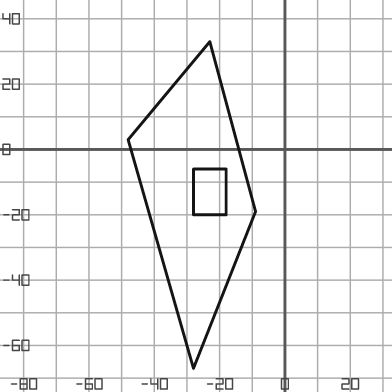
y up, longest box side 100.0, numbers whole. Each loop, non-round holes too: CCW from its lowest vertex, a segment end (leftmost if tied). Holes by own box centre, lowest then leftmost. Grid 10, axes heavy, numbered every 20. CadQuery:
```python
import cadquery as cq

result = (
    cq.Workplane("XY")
    .moveTo(-28.0, -67.0)
    .lineTo(-9.0, -19.0)
    .lineTo(-23.0, 33.0)
    .lineTo(-48.0, 3.0)
    .close()
    .moveTo(-28.0, -20.0)
    .lineTo(-18.0, -20.0)
    .lineTo(-18.0, -6.0)
    .lineTo(-28.0, -6.0)
    .close()
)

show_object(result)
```